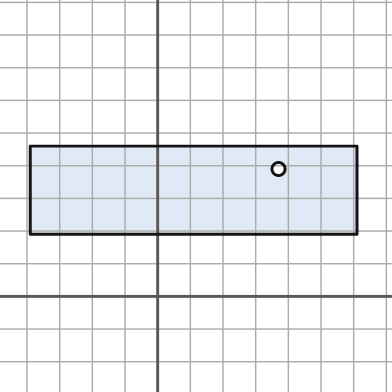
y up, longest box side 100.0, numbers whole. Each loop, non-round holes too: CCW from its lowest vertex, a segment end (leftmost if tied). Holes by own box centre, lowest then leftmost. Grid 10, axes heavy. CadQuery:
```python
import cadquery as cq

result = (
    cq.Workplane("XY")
    .moveTo(-39.0, 19.0)
    .lineTo(61.0, 19.0)
    .lineTo(61.0, 46.0)
    .lineTo(-39.0, 46.0)
    .close()
    .moveTo(37.0, 39.0)
    .circle(2.0)
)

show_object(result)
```